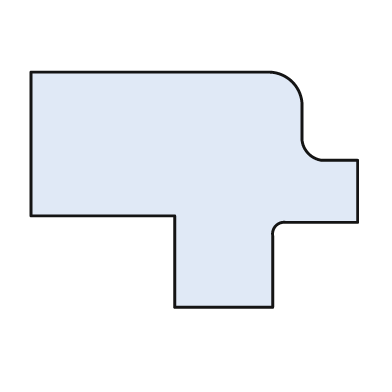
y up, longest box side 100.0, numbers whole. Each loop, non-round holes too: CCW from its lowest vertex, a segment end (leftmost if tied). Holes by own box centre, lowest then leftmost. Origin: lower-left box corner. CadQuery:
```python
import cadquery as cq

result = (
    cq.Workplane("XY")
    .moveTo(44.0, 0.0)
    .lineTo(74.0, 0.0)
    .lineTo(74.0, 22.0)
    .threePointArc((75.0, 25.0), (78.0, 26.0))
    .lineTo(100.0, 26.0)
    .lineTo(100.0, 45.0)
    .lineTo(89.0, 45.0)
    .threePointArc((85.0, 47.0), (83.0, 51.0))
    .lineTo(83.0, 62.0)
    .threePointArc((80.0, 69.0), (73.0, 72.0))
    .lineTo(0.0, 72.0)
    .lineTo(0.0, 28.0)
    .lineTo(44.0, 28.0)
    .close()
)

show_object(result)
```